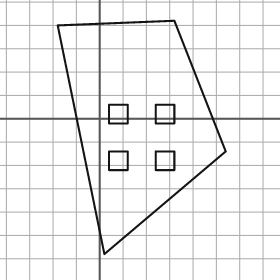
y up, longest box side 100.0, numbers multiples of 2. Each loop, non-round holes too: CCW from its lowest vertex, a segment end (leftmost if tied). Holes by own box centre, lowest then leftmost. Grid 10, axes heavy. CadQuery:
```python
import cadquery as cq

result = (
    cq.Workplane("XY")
    .moveTo(2.0, -58.0)
    .lineTo(54.0, -14.0)
    .lineTo(32.0, 42.0)
    .lineTo(-18.0, 40.0)
    .close()
    .moveTo(4.0, -22.0)
    .lineTo(12.0, -22.0)
    .lineTo(12.0, -14.0)
    .lineTo(4.0, -14.0)
    .close()
    .moveTo(24.0, -22.0)
    .lineTo(32.0, -22.0)
    .lineTo(32.0, -14.0)
    .lineTo(24.0, -14.0)
    .close()
    .moveTo(4.0, -2.0)
    .lineTo(12.0, -2.0)
    .lineTo(12.0, 6.0)
    .lineTo(4.0, 6.0)
    .close()
    .moveTo(24.0, -2.0)
    .lineTo(32.0, -2.0)
    .lineTo(32.0, 6.0)
    .lineTo(24.0, 6.0)
    .close()
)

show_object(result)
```